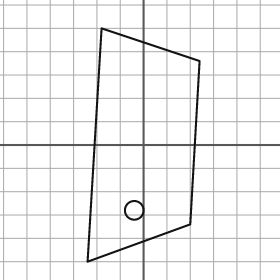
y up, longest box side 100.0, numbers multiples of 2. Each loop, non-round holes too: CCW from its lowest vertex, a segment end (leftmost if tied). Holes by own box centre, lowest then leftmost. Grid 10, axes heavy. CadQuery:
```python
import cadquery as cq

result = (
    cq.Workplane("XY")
    .moveTo(-24.0, -50.0)
    .lineTo(20.0, -34.0)
    .lineTo(24.0, 36.0)
    .lineTo(-18.0, 50.0)
    .close()
    .moveTo(-4.0, -28.0)
    .circle(4.0)
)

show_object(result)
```